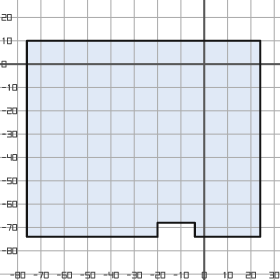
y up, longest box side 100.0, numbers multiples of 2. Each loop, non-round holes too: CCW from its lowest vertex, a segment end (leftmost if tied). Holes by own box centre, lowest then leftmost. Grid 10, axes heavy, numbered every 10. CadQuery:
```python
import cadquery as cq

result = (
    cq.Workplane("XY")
    .moveTo(-76.0, -74.0)
    .lineTo(-20.0, -74.0)
    .lineTo(-20.0, -68.0)
    .lineTo(-4.0, -68.0)
    .lineTo(-4.0, -74.0)
    .lineTo(24.0, -74.0)
    .lineTo(24.0, 10.0)
    .lineTo(-76.0, 10.0)
    .close()
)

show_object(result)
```